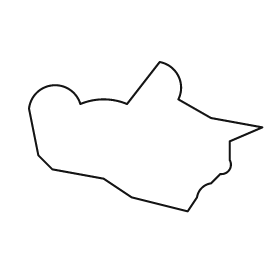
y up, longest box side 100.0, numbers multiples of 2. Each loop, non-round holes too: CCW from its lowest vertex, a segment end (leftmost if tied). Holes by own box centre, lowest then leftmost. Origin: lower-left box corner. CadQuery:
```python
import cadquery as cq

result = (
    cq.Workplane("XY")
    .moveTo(68.0, 0.0)
    .lineTo(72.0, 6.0)
    .threePointArc((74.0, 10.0), (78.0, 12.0))
    .lineTo(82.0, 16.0)
    .threePointArc((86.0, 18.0), (86.0, 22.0))
    .lineTo(86.0, 30.0)
    .lineTo(100.0, 36.0)
    .lineTo(78.0, 40.0)
    .lineTo(64.0, 48.0)
    .threePointArc((64.0, 58.0), (56.0, 64.0))
    .lineTo(42.0, 46.0)
    .threePointArc((32.0, 48.0), (22.0, 46.0))
    .threePointArc((10.0, 54.0), (0.0, 44.0))
    .lineTo(4.0, 24.0)
    .lineTo(10.0, 18.0)
    .lineTo(32.0, 14.0)
    .lineTo(44.0, 6.0)
    .close()
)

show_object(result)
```